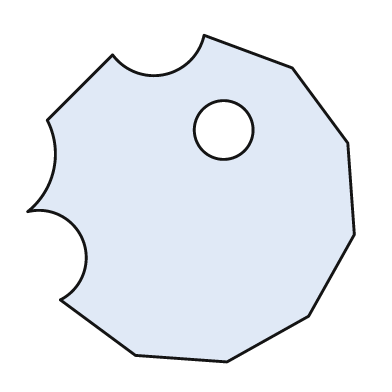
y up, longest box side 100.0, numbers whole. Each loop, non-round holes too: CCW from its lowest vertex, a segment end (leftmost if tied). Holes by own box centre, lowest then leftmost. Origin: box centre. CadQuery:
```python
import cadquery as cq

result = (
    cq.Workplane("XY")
    .moveTo(11.0, -50.0)
    .lineTo(36.0, -36.0)
    .lineTo(50.0, -11.0)
    .lineTo(48.0, 17.0)
    .lineTo(31.0, 40.0)
    .lineTo(4.0, 50.0)
    .threePointArc((-8.0, 38.0), (-24.0, 44.0))
    .lineTo(-44.0, 24.0)
    .threePointArc((-42.0, 9.0), (-50.0, -4.0))
    .threePointArc((-33.0, -13.0), (-40.0, -31.0))
    .lineTo(-17.0, -48.0)
    .close()
    .moveTo(10.0, 21.0)
    .circle(9.0)
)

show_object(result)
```